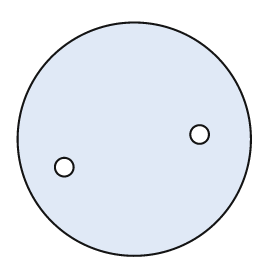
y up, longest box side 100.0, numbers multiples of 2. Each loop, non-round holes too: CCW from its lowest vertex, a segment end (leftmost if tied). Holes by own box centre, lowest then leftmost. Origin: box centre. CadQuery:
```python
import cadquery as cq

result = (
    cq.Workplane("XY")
    .moveTo(0.0, 0.0)
    .circle(50.0)
    .moveTo(-30.0, -12.0)
    .circle(4.0)
    .moveTo(28.0, 2.0)
    .circle(4.0)
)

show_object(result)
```